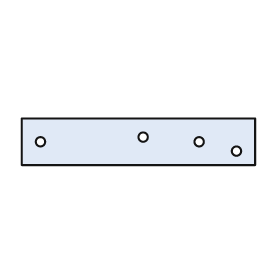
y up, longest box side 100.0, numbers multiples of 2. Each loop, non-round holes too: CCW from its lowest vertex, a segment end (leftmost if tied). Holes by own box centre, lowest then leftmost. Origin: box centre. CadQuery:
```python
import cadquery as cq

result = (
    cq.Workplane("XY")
    .moveTo(-50.0, -10.0)
    .lineTo(50.0, -10.0)
    .lineTo(50.0, 10.0)
    .lineTo(-50.0, 10.0)
    .close()
    .moveTo(42.0, -4.0)
    .circle(2.0)
    .moveTo(-42.0, 0.0)
    .circle(2.0)
    .moveTo(26.0, 0.0)
    .circle(2.0)
    .moveTo(2.0, 2.0)
    .circle(2.0)
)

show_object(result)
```